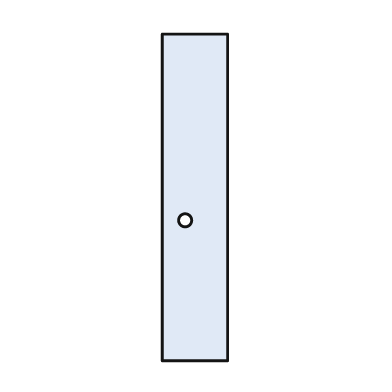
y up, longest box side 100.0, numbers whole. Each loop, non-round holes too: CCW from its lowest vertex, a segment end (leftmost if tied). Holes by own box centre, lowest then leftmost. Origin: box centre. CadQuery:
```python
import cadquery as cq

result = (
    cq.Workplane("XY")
    .moveTo(-10.0, -50.0)
    .lineTo(10.0, -50.0)
    .lineTo(10.0, 50.0)
    .lineTo(-10.0, 50.0)
    .close()
    .moveTo(-3.0, -7.0)
    .circle(2.0)
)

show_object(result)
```